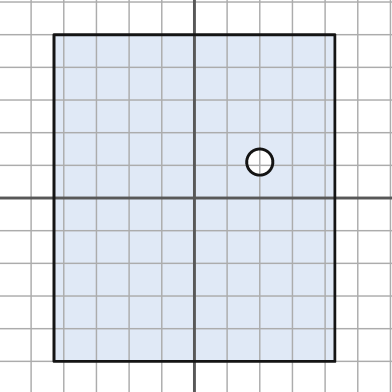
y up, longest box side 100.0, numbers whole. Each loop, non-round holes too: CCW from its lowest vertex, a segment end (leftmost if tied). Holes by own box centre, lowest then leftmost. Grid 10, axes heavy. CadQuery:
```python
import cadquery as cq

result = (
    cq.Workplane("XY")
    .moveTo(-43.0, -50.0)
    .lineTo(43.0, -50.0)
    .lineTo(43.0, 50.0)
    .lineTo(-43.0, 50.0)
    .close()
    .moveTo(20.0, 11.0)
    .circle(4.0)
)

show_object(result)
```